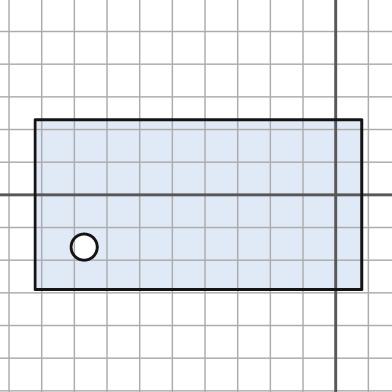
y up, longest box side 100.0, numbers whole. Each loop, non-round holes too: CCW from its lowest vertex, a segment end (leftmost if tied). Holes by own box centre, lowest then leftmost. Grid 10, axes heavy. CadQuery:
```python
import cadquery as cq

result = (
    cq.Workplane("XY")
    .moveTo(-92.0, -29.0)
    .lineTo(8.0, -29.0)
    .lineTo(8.0, 23.0)
    .lineTo(-92.0, 23.0)
    .close()
    .moveTo(-77.0, -16.0)
    .circle(4.0)
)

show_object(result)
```